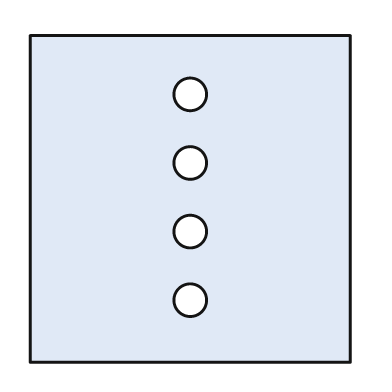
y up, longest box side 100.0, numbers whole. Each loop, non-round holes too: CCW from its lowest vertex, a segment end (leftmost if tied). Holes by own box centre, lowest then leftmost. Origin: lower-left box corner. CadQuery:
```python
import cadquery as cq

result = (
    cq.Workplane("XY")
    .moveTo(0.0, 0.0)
    .lineTo(98.0, 0.0)
    .lineTo(98.0, 100.0)
    .lineTo(0.0, 100.0)
    .close()
    .moveTo(49.0, 19.0)
    .circle(5.0)
    .moveTo(49.0, 40.0)
    .circle(5.0)
    .moveTo(49.0, 61.0)
    .circle(5.0)
    .moveTo(49.0, 82.0)
    .circle(5.0)
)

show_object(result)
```